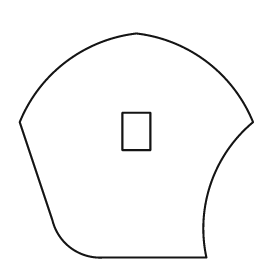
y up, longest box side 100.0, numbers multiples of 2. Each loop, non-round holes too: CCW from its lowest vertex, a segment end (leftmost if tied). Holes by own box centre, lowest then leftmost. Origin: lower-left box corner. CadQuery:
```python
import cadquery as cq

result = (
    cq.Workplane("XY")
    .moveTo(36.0, 0.0)
    .lineTo(80.0, 0.0)
    .threePointArc((82.0, 32.0), (100.0, 58.0))
    .threePointArc((80.0, 84.0), (50.0, 96.0))
    .threePointArc((20.0, 84.0), (0.0, 58.0))
    .lineTo(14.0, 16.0)
    .threePointArc((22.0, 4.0), (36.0, 0.0))
    .close()
    .moveTo(44.0, 46.0)
    .lineTo(56.0, 46.0)
    .lineTo(56.0, 62.0)
    .lineTo(44.0, 62.0)
    .close()
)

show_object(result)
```